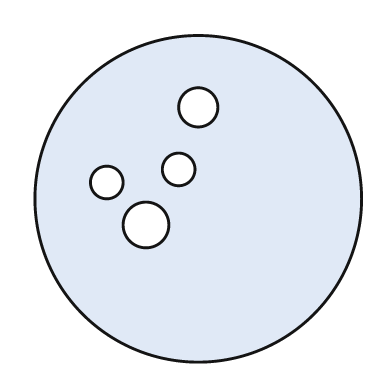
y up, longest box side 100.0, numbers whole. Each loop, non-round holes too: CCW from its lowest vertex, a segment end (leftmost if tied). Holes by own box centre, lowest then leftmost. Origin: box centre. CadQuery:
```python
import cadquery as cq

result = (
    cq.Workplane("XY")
    .moveTo(0.0, 0.0)
    .circle(50.0)
    .moveTo(-16.0, -8.0)
    .circle(7.0)
    .moveTo(-28.0, 5.0)
    .circle(5.0)
    .moveTo(-6.0, 9.0)
    .circle(5.0)
    .moveTo(0.0, 28.0)
    .circle(6.0)
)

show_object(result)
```